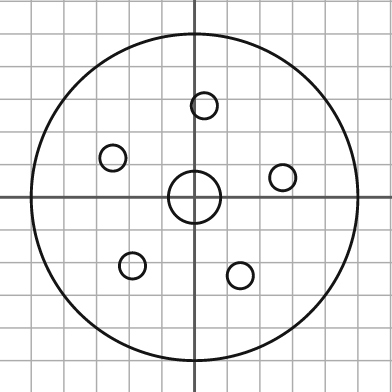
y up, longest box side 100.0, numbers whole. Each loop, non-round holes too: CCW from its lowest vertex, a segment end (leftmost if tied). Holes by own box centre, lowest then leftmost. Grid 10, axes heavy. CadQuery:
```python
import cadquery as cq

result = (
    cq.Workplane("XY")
    .moveTo(0.0, 0.0)
    .circle(50.0)
    .moveTo(14.0, -24.0)
    .circle(4.0)
    .moveTo(-19.0, -21.0)
    .circle(4.0)
    .moveTo(0.0, 0.0)
    .circle(8.0)
    .moveTo(27.0, 6.0)
    .circle(4.0)
    .moveTo(-25.0, 12.0)
    .circle(4.0)
    .moveTo(3.0, 28.0)
    .circle(4.0)
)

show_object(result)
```